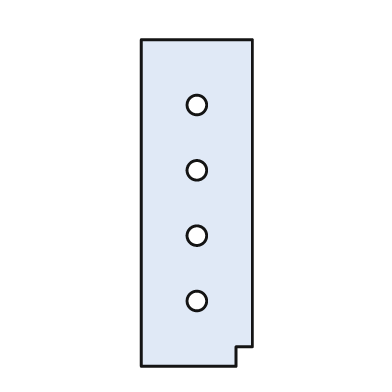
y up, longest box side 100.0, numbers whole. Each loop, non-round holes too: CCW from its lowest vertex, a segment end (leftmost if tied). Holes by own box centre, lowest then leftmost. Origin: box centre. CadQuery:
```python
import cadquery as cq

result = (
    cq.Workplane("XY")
    .moveTo(-17.0, -50.0)
    .lineTo(12.0, -50.0)
    .lineTo(12.0, -44.0)
    .lineTo(17.0, -44.0)
    .lineTo(17.0, 50.0)
    .lineTo(-17.0, 50.0)
    .close()
    .moveTo(0.0, -30.0)
    .circle(3.0)
    .moveTo(0.0, -10.0)
    .circle(3.0)
    .moveTo(0.0, 10.0)
    .circle(3.0)
    .moveTo(0.0, 30.0)
    .circle(3.0)
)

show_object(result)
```